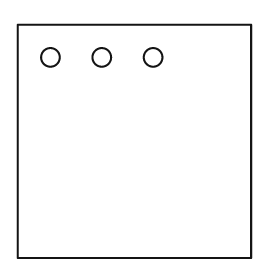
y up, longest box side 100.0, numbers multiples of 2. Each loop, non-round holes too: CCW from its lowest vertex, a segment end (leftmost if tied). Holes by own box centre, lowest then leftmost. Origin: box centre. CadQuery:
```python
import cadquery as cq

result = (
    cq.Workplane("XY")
    .moveTo(-50.0, -50.0)
    .lineTo(50.0, -50.0)
    .lineTo(50.0, 50.0)
    .lineTo(-50.0, 50.0)
    .close()
    .moveTo(-36.0, 36.0)
    .circle(4.0)
    .moveTo(-14.0, 36.0)
    .circle(4.0)
    .moveTo(8.0, 36.0)
    .circle(4.0)
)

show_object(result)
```